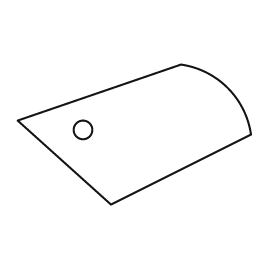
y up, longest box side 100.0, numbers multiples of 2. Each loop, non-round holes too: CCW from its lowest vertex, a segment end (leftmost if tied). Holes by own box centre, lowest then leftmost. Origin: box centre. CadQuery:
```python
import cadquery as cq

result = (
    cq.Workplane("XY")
    .moveTo(-10.0, -30.0)
    .lineTo(50.0, 0.0)
    .threePointArc((40.0, 20.0), (20.0, 30.0))
    .lineTo(-50.0, 6.0)
    .close()
    .moveTo(-22.0, 2.0)
    .circle(4.0)
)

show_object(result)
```